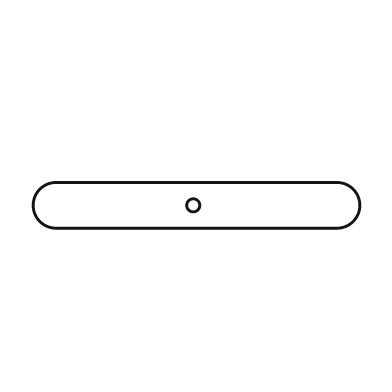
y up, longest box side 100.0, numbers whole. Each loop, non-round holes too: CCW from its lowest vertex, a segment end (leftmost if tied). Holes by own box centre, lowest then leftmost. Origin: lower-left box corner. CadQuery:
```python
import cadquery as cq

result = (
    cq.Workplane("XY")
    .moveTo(7.0, 0.0)
    .lineTo(93.0, 0.0)
    .threePointArc((100.0, 7.0), (93.0, 14.0))
    .lineTo(7.0, 14.0)
    .threePointArc((0.0, 7.0), (7.0, 0.0))
    .close()
    .moveTo(49.0, 7.0)
    .circle(2.0)
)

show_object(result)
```